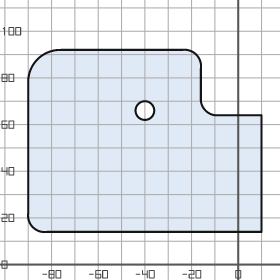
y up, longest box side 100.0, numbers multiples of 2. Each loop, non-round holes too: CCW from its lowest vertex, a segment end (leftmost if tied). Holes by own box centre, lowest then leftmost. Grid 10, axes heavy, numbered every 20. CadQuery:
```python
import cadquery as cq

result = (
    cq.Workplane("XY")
    .moveTo(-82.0, 14.0)
    .lineTo(10.0, 14.0)
    .lineTo(10.0, 64.0)
    .lineTo(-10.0, 64.0)
    .threePointArc((-14.0, 66.0), (-16.0, 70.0))
    .lineTo(-16.0, 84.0)
    .threePointArc((-18.0, 90.0), (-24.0, 92.0))
    .lineTo(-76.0, 92.0)
    .threePointArc((-86.0, 88.0), (-90.0, 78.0))
    .lineTo(-90.0, 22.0)
    .threePointArc((-88.0, 16.0), (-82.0, 14.0))
    .close()
    .moveTo(-40.0, 66.0)
    .circle(4.0)
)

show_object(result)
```